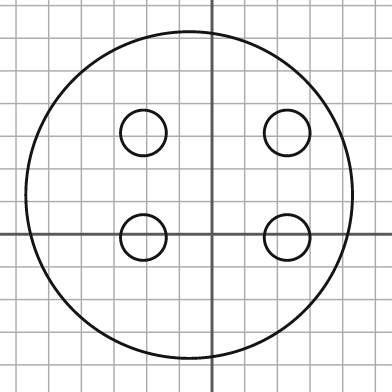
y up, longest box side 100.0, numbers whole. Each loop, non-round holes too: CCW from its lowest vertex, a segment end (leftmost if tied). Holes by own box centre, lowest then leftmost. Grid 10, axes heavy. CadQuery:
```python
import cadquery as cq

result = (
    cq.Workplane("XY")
    .moveTo(-7.0, 12.0)
    .circle(50.0)
    .moveTo(-21.0, -1.0)
    .circle(7.0)
    .moveTo(23.0, -1.0)
    .circle(7.0)
    .moveTo(-21.0, 31.0)
    .circle(7.0)
    .moveTo(23.0, 31.0)
    .circle(7.0)
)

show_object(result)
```